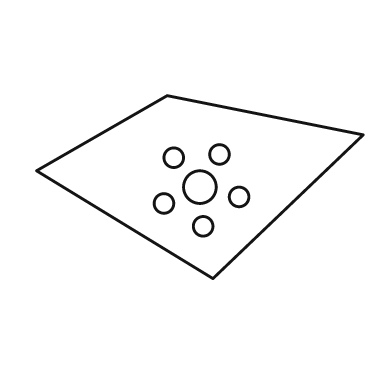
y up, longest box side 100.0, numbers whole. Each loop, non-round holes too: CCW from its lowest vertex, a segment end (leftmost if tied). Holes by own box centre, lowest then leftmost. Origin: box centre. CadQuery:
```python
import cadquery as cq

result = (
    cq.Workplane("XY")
    .moveTo(4.0, -28.0)
    .lineTo(50.0, 16.0)
    .lineTo(-10.0, 28.0)
    .lineTo(-50.0, 5.0)
    .close()
    .moveTo(1.0, -12.0)
    .circle(3.0)
    .moveTo(-11.0, -5.0)
    .circle(3.0)
    .moveTo(12.0, -3.0)
    .circle(3.0)
    .moveTo(0.0, 0.0)
    .circle(5.0)
    .moveTo(-8.0, 9.0)
    .circle(3.0)
    .moveTo(6.0, 10.0)
    .circle(3.0)
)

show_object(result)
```